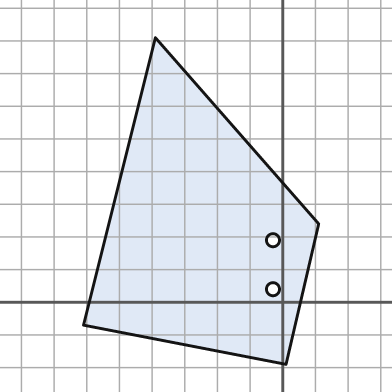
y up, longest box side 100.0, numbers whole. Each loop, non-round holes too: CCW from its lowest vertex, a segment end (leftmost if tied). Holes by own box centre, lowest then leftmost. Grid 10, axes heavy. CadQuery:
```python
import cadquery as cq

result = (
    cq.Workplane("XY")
    .moveTo(1.0, -19.0)
    .lineTo(11.0, 24.0)
    .lineTo(-39.0, 81.0)
    .lineTo(-61.0, -7.0)
    .close()
    .moveTo(-3.0, 4.0)
    .circle(2.0)
    .moveTo(-3.0, 19.0)
    .circle(2.0)
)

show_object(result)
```